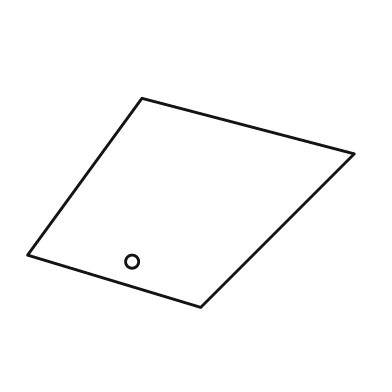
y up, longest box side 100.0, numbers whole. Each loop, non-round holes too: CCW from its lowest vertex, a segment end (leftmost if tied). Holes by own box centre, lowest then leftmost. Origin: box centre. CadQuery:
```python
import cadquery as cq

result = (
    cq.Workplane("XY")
    .moveTo(3.0, -32.0)
    .lineTo(50.0, 15.0)
    .lineTo(-15.0, 32.0)
    .lineTo(-50.0, -16.0)
    .close()
    .moveTo(-18.0, -18.0)
    .circle(2.0)
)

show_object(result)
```